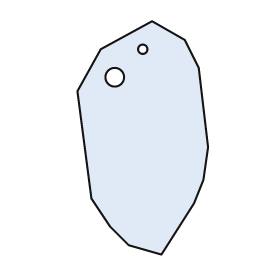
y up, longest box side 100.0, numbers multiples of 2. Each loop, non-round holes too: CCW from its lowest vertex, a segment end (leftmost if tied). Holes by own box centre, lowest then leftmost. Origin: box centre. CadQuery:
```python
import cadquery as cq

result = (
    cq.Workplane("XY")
    .moveTo(8.0, -50.0)
    .lineTo(22.0, -28.0)
    .lineTo(26.0, -18.0)
    .lineTo(28.0, -4.0)
    .lineTo(24.0, 30.0)
    .lineTo(18.0, 42.0)
    .lineTo(4.0, 50.0)
    .lineTo(-18.0, 38.0)
    .lineTo(-28.0, 20.0)
    .lineTo(-22.0, -26.0)
    .lineTo(-14.0, -38.0)
    .lineTo(-6.0, -46.0)
    .close()
    .moveTo(-12.0, 26.0)
    .circle(4.0)
    .moveTo(0.0, 38.0)
    .circle(2.0)
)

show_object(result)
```